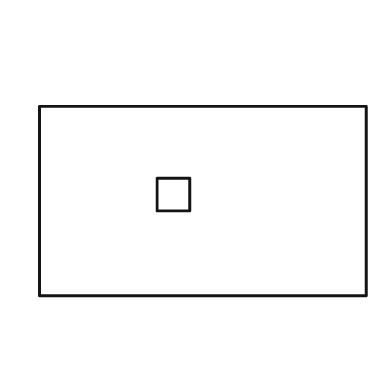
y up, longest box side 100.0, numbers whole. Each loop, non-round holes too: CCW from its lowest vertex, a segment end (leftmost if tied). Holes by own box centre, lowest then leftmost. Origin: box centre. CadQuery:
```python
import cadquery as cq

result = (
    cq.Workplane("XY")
    .moveTo(-50.0, -29.0)
    .lineTo(50.0, -29.0)
    .lineTo(50.0, 29.0)
    .lineTo(-50.0, 29.0)
    .close()
    .moveTo(-14.0, -3.0)
    .lineTo(-4.0, -3.0)
    .lineTo(-4.0, 7.0)
    .lineTo(-14.0, 7.0)
    .close()
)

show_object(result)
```